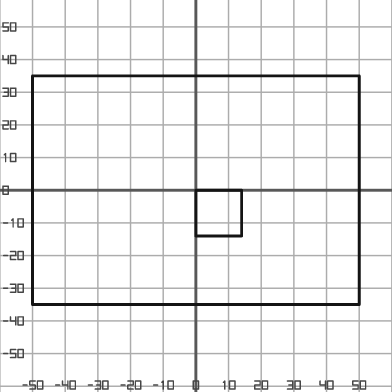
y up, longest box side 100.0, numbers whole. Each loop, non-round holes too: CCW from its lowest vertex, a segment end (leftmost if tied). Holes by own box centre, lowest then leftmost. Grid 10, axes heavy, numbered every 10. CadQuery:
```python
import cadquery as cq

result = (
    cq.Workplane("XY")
    .moveTo(-50.0, -35.0)
    .lineTo(50.0, -35.0)
    .lineTo(50.0, 35.0)
    .lineTo(-50.0, 35.0)
    .close()
    .moveTo(0.0, -14.0)
    .lineTo(14.0, -14.0)
    .lineTo(14.0, 0.0)
    .lineTo(0.0, 0.0)
    .close()
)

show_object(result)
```